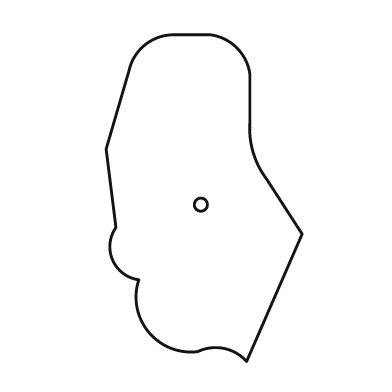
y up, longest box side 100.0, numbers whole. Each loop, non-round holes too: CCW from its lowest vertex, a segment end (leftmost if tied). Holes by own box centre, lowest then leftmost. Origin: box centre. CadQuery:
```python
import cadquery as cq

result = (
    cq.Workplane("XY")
    .moveTo(13.0, -50.0)
    .lineTo(30.0, -11.0)
    .lineTo(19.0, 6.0)
    .threePointArc((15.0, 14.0), (14.0, 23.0))
    .lineTo(14.0, 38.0)
    .threePointArc((10.0, 46.0), (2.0, 50.0))
    .lineTo(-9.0, 50.0)
    .threePointArc((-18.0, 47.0), (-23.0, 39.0))
    .lineTo(-30.0, 15.0)
    .lineTo(-27.0, -9.0)
    .threePointArc((-28.0, -19.0), (-20.0, -25.0))
    .threePointArc((-17.0, -41.0), (-2.0, -47.0))
    .threePointArc((6.0, -46.0), (13.0, -50.0))
    .close()
    .moveTo(-1.0, -2.0)
    .circle(2.0)
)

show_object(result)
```